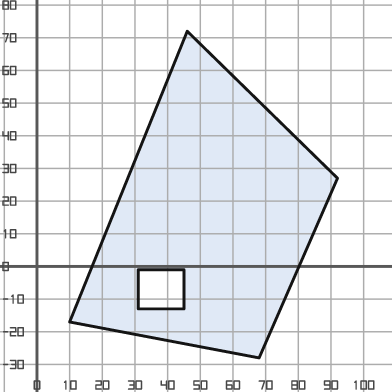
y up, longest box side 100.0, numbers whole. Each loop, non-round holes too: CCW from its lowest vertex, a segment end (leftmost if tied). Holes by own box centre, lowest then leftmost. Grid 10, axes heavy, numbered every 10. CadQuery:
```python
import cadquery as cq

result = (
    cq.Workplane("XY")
    .moveTo(68.0, -28.0)
    .lineTo(92.0, 27.0)
    .lineTo(46.0, 72.0)
    .lineTo(10.0, -17.0)
    .close()
    .moveTo(31.0, -13.0)
    .lineTo(45.0, -13.0)
    .lineTo(45.0, -1.0)
    .lineTo(31.0, -1.0)
    .close()
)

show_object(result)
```